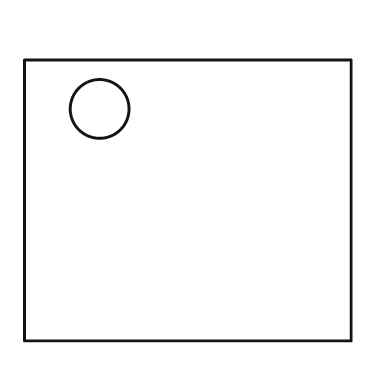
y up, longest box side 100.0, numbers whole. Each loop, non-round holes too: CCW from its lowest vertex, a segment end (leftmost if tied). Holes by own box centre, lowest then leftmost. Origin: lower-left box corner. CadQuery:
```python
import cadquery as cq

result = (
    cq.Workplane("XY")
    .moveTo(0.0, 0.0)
    .lineTo(100.0, 0.0)
    .lineTo(100.0, 86.0)
    .lineTo(0.0, 86.0)
    .close()
    .moveTo(23.0, 71.0)
    .circle(9.0)
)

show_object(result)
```